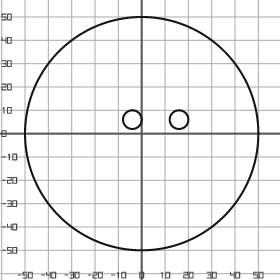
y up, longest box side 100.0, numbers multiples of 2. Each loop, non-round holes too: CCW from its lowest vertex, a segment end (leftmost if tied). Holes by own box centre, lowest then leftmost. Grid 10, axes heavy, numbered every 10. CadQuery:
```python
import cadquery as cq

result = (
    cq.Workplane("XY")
    .moveTo(0.0, 0.0)
    .circle(50.0)
    .moveTo(-4.0, 6.0)
    .circle(4.0)
    .moveTo(16.0, 6.0)
    .circle(4.0)
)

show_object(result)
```